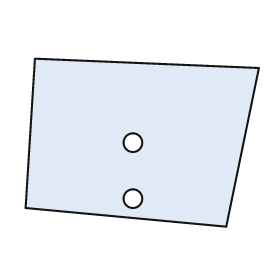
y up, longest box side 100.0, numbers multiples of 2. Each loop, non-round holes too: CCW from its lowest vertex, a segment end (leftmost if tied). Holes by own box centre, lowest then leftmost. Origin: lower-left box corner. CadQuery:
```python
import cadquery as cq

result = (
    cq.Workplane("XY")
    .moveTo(86.0, 0.0)
    .lineTo(100.0, 68.0)
    .lineTo(4.0, 72.0)
    .lineTo(0.0, 8.0)
    .close()
    .moveTo(46.0, 12.0)
    .circle(4.0)
    .moveTo(46.0, 36.0)
    .circle(4.0)
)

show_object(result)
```